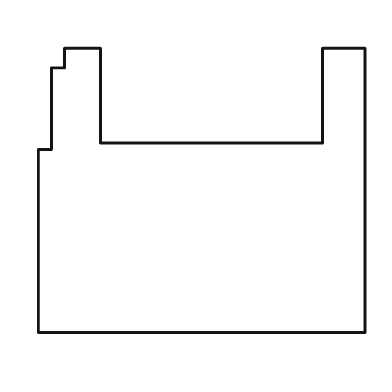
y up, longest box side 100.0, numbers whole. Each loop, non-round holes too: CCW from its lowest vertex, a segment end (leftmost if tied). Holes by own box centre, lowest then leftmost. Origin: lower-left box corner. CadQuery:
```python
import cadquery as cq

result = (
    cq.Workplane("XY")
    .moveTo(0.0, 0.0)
    .lineTo(100.0, 0.0)
    .lineTo(100.0, 87.0)
    .lineTo(87.0, 87.0)
    .lineTo(87.0, 58.0)
    .lineTo(19.0, 58.0)
    .lineTo(19.0, 87.0)
    .lineTo(8.0, 87.0)
    .lineTo(8.0, 81.0)
    .lineTo(4.0, 81.0)
    .lineTo(4.0, 56.0)
    .lineTo(0.0, 56.0)
    .close()
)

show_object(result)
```